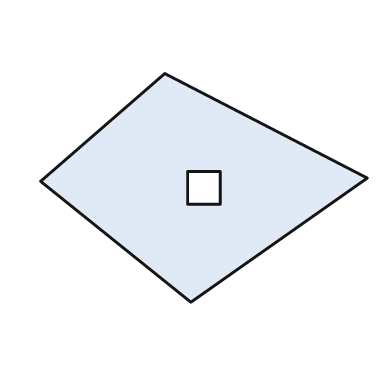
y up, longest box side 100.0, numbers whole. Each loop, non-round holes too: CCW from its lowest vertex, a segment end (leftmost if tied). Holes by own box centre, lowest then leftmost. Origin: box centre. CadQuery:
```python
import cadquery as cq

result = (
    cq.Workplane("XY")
    .moveTo(-4.0, -35.0)
    .lineTo(50.0, 3.0)
    .lineTo(-12.0, 35.0)
    .lineTo(-50.0, 2.0)
    .close()
    .moveTo(-5.0, -5.0)
    .lineTo(5.0, -5.0)
    .lineTo(5.0, 5.0)
    .lineTo(-5.0, 5.0)
    .close()
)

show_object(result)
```